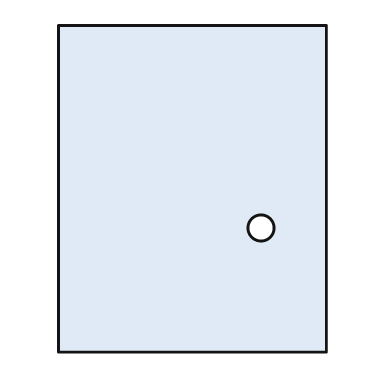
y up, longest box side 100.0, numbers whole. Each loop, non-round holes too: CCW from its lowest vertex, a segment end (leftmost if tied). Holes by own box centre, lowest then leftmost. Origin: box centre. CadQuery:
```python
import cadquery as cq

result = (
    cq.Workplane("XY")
    .moveTo(-41.0, -50.0)
    .lineTo(41.0, -50.0)
    .lineTo(41.0, 50.0)
    .lineTo(-41.0, 50.0)
    .close()
    .moveTo(21.0, -12.0)
    .circle(4.0)
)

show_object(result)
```